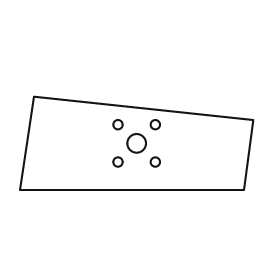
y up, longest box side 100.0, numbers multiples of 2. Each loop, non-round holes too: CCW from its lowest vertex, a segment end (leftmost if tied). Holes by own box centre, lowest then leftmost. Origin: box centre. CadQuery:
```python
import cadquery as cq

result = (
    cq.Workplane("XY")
    .moveTo(-50.0, -20.0)
    .lineTo(46.0, -20.0)
    .lineTo(50.0, 10.0)
    .lineTo(-44.0, 20.0)
    .close()
    .moveTo(-8.0, -8.0)
    .circle(2.0)
    .moveTo(8.0, -8.0)
    .circle(2.0)
    .moveTo(0.0, 0.0)
    .circle(4.0)
    .moveTo(-8.0, 8.0)
    .circle(2.0)
    .moveTo(8.0, 8.0)
    .circle(2.0)
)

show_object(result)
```